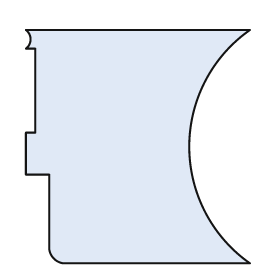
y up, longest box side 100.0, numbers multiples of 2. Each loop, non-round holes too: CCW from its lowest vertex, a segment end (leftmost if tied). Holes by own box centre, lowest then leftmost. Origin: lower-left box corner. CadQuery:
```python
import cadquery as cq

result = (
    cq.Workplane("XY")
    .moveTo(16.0, 0.0)
    .lineTo(96.0, 0.0)
    .threePointArc((70.0, 50.0), (96.0, 100.0))
    .lineTo(0.0, 100.0)
    .threePointArc((2.0, 96.0), (0.0, 92.0))
    .lineTo(4.0, 92.0)
    .lineTo(4.0, 56.0)
    .lineTo(0.0, 56.0)
    .lineTo(0.0, 38.0)
    .lineTo(10.0, 38.0)
    .lineTo(10.0, 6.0)
    .threePointArc((12.0, 2.0), (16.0, 0.0))
    .close()
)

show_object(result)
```